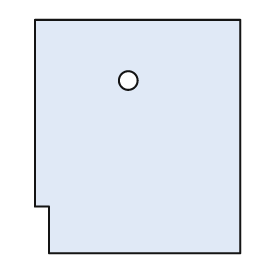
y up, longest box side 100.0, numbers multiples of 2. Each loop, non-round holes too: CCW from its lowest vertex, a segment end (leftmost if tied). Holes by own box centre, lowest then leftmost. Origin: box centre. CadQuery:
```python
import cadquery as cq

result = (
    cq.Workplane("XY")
    .moveTo(-38.0, -50.0)
    .lineTo(44.0, -50.0)
    .lineTo(44.0, 50.0)
    .lineTo(-44.0, 50.0)
    .lineTo(-44.0, -30.0)
    .lineTo(-38.0, -30.0)
    .close()
    .moveTo(-4.0, 24.0)
    .circle(4.0)
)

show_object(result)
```